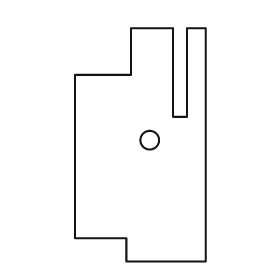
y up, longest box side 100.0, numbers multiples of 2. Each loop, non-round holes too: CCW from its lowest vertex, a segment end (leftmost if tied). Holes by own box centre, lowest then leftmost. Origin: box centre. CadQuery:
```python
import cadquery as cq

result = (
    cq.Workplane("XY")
    .moveTo(-6.0, -50.0)
    .lineTo(28.0, -50.0)
    .lineTo(28.0, 50.0)
    .lineTo(20.0, 50.0)
    .lineTo(20.0, 12.0)
    .lineTo(14.0, 12.0)
    .lineTo(14.0, 50.0)
    .lineTo(-4.0, 50.0)
    .lineTo(-4.0, 30.0)
    .lineTo(-28.0, 30.0)
    .lineTo(-28.0, -40.0)
    .lineTo(-6.0, -40.0)
    .close()
    .moveTo(4.0, 2.0)
    .circle(4.0)
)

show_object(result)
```